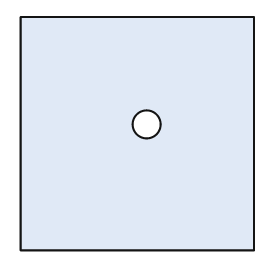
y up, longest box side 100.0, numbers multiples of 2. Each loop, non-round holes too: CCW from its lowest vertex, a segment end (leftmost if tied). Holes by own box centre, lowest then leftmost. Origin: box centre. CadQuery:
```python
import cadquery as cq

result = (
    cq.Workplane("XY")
    .moveTo(-50.0, -50.0)
    .lineTo(50.0, -50.0)
    .lineTo(50.0, 50.0)
    .lineTo(-50.0, 50.0)
    .close()
    .moveTo(4.0, 4.0)
    .circle(6.0)
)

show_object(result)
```